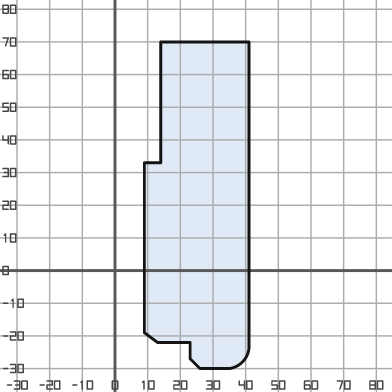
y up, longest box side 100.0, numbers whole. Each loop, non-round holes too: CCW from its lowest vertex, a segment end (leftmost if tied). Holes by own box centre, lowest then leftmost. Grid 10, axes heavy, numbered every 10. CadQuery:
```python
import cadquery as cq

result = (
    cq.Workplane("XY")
    .moveTo(26.0, -30.0)
    .lineTo(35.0, -30.0)
    .threePointArc((39.0, -28.0), (41.0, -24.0))
    .lineTo(41.0, 70.0)
    .lineTo(14.0, 70.0)
    .lineTo(14.0, 33.0)
    .lineTo(9.0, 33.0)
    .lineTo(9.0, -19.0)
    .lineTo(13.0, -22.0)
    .lineTo(23.0, -22.0)
    .lineTo(23.0, -27.0)
    .close()
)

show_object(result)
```